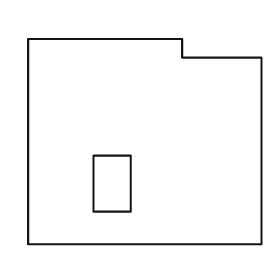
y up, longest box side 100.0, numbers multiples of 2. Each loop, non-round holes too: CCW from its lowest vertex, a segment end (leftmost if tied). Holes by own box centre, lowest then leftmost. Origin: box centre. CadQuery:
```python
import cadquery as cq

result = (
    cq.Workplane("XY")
    .moveTo(-50.0, -44.0)
    .lineTo(50.0, -44.0)
    .lineTo(50.0, 36.0)
    .lineTo(16.0, 36.0)
    .lineTo(16.0, 44.0)
    .lineTo(-50.0, 44.0)
    .close()
    .moveTo(-22.0, -30.0)
    .lineTo(-6.0, -30.0)
    .lineTo(-6.0, -6.0)
    .lineTo(-22.0, -6.0)
    .close()
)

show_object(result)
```